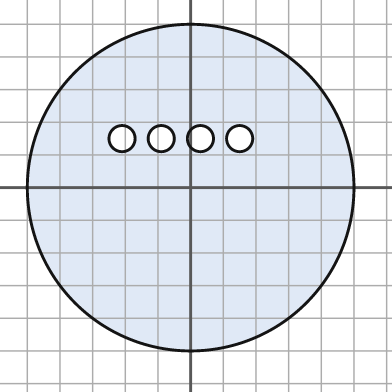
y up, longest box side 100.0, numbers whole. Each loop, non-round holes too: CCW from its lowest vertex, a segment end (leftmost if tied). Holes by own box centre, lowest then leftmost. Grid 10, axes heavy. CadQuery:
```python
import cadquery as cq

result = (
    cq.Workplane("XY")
    .moveTo(0.0, 0.0)
    .circle(50.0)
    .moveTo(-21.0, 15.0)
    .circle(4.0)
    .moveTo(-9.0, 15.0)
    .circle(4.0)
    .moveTo(3.0, 15.0)
    .circle(4.0)
    .moveTo(15.0, 15.0)
    .circle(4.0)
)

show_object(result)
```